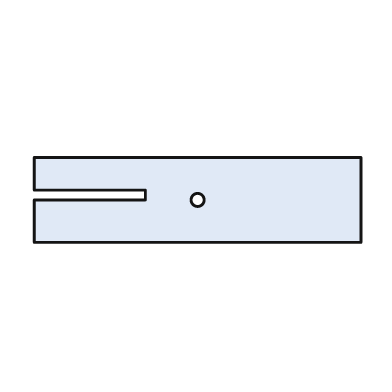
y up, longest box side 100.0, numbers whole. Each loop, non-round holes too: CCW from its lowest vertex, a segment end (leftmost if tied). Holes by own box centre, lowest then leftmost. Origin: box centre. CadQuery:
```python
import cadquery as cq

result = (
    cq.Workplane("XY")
    .moveTo(-50.0, -13.0)
    .lineTo(50.0, -13.0)
    .lineTo(50.0, 13.0)
    .lineTo(-50.0, 13.0)
    .lineTo(-50.0, 3.0)
    .lineTo(-16.0, 3.0)
    .lineTo(-16.0, 0.0)
    .lineTo(-50.0, 0.0)
    .close()
    .moveTo(0.0, 0.0)
    .circle(2.0)
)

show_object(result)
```